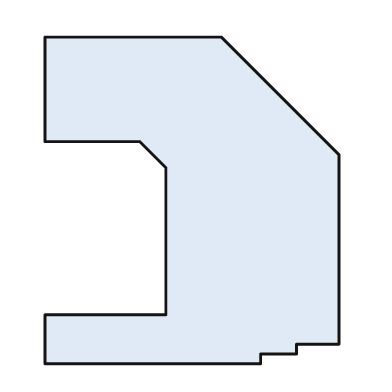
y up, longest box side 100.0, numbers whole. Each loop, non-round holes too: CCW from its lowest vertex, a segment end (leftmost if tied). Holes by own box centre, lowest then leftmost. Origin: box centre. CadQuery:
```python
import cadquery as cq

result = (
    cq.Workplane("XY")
    .moveTo(-45.0, -50.0)
    .lineTo(21.0, -50.0)
    .lineTo(21.0, -47.0)
    .lineTo(32.0, -47.0)
    .lineTo(32.0, -44.0)
    .lineTo(45.0, -44.0)
    .lineTo(45.0, 14.0)
    .lineTo(9.0, 50.0)
    .lineTo(-45.0, 50.0)
    .lineTo(-45.0, 18.0)
    .lineTo(-16.0, 18.0)
    .lineTo(-8.0, 10.0)
    .lineTo(-8.0, -35.0)
    .lineTo(-45.0, -35.0)
    .close()
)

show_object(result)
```